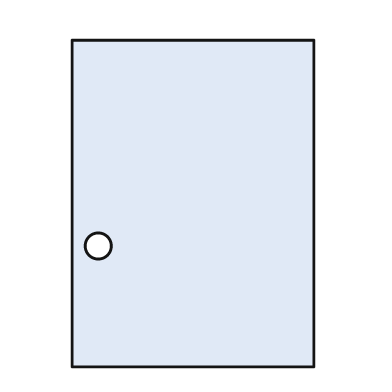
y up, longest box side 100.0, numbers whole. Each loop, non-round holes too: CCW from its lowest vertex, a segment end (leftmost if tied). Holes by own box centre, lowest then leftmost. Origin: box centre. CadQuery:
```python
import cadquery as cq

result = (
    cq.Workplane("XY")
    .moveTo(-37.0, -50.0)
    .lineTo(37.0, -50.0)
    .lineTo(37.0, 50.0)
    .lineTo(-37.0, 50.0)
    .close()
    .moveTo(-29.0, -13.0)
    .circle(4.0)
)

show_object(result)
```